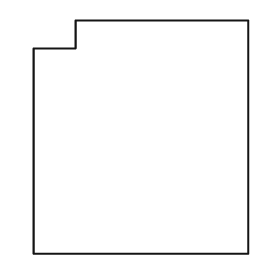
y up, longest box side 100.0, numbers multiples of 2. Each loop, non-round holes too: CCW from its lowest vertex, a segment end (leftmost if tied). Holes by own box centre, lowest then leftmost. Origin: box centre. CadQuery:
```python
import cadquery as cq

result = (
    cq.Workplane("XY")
    .moveTo(-46.0, -50.0)
    .lineTo(46.0, -50.0)
    .lineTo(46.0, 50.0)
    .lineTo(-28.0, 50.0)
    .lineTo(-28.0, 38.0)
    .lineTo(-46.0, 38.0)
    .close()
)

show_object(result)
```